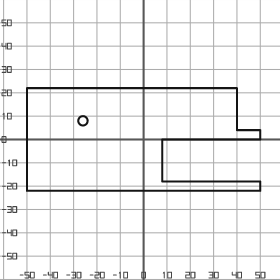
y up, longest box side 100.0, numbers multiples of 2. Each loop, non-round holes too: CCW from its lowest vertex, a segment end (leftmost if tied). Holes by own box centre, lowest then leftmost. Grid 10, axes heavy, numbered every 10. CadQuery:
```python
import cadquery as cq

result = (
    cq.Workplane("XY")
    .moveTo(-50.0, -22.0)
    .lineTo(50.0, -22.0)
    .lineTo(50.0, -18.0)
    .lineTo(8.0, -18.0)
    .lineTo(8.0, 0.0)
    .lineTo(50.0, 0.0)
    .lineTo(50.0, 4.0)
    .lineTo(40.0, 4.0)
    .lineTo(40.0, 22.0)
    .lineTo(-50.0, 22.0)
    .close()
    .moveTo(-26.0, 8.0)
    .circle(2.0)
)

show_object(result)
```